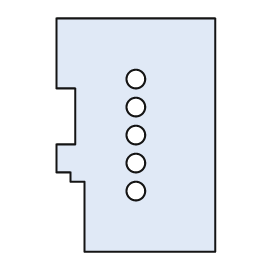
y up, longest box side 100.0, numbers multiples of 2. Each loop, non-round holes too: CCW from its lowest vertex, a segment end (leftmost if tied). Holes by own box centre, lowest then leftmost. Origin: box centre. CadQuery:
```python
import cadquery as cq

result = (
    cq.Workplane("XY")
    .moveTo(-22.0, -50.0)
    .lineTo(34.0, -50.0)
    .lineTo(34.0, 50.0)
    .lineTo(-34.0, 50.0)
    .lineTo(-34.0, 20.0)
    .lineTo(-26.0, 20.0)
    .lineTo(-26.0, -4.0)
    .lineTo(-34.0, -4.0)
    .lineTo(-34.0, -16.0)
    .lineTo(-28.0, -16.0)
    .lineTo(-28.0, -20.0)
    .lineTo(-22.0, -20.0)
    .close()
    .moveTo(0.0, -24.0)
    .circle(4.0)
    .moveTo(0.0, -12.0)
    .circle(4.0)
    .moveTo(0.0, 0.0)
    .circle(4.0)
    .moveTo(0.0, 12.0)
    .circle(4.0)
    .moveTo(0.0, 24.0)
    .circle(4.0)
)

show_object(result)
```